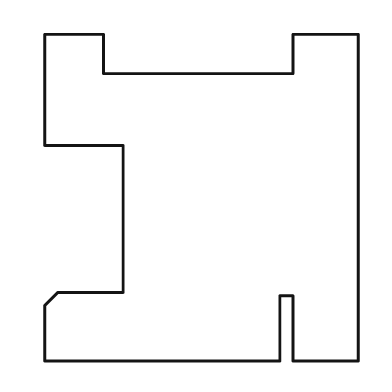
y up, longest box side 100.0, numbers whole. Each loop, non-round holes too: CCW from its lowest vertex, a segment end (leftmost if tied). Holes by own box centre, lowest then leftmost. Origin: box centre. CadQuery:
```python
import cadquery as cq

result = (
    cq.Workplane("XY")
    .moveTo(-48.0, -50.0)
    .lineTo(24.0, -50.0)
    .lineTo(24.0, -30.0)
    .lineTo(28.0, -30.0)
    .lineTo(28.0, -50.0)
    .lineTo(48.0, -50.0)
    .lineTo(48.0, 50.0)
    .lineTo(28.0, 50.0)
    .lineTo(28.0, 38.0)
    .lineTo(-30.0, 38.0)
    .lineTo(-30.0, 50.0)
    .lineTo(-48.0, 50.0)
    .lineTo(-48.0, 16.0)
    .lineTo(-24.0, 16.0)
    .lineTo(-24.0, -29.0)
    .lineTo(-44.0, -29.0)
    .lineTo(-48.0, -33.0)
    .close()
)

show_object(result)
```